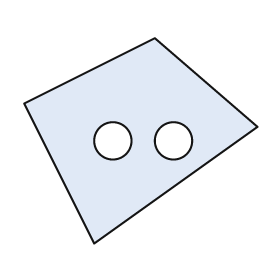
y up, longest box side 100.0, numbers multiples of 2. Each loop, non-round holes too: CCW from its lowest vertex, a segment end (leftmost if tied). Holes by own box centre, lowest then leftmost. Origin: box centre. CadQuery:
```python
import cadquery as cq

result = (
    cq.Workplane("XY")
    .moveTo(-20.0, -44.0)
    .lineTo(50.0, 6.0)
    .lineTo(6.0, 44.0)
    .lineTo(-50.0, 16.0)
    .close()
    .moveTo(-12.0, 0.0)
    .circle(8.0)
    .moveTo(14.0, 0.0)
    .circle(8.0)
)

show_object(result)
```